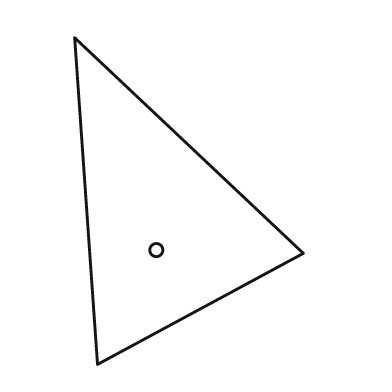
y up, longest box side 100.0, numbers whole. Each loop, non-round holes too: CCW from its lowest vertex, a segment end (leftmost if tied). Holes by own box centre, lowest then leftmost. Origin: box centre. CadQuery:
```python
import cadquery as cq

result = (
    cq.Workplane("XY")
    .moveTo(-28.0, -50.0)
    .lineTo(35.0, -16.0)
    .lineTo(-35.0, 50.0)
    .close()
    .moveTo(-10.0, -15.0)
    .circle(2.0)
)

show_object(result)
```